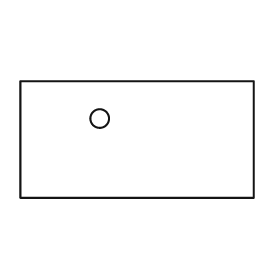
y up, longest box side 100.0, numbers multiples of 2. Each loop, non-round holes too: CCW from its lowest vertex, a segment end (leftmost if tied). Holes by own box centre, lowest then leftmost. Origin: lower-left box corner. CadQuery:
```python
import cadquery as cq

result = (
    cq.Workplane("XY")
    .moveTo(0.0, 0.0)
    .lineTo(100.0, 0.0)
    .lineTo(100.0, 50.0)
    .lineTo(0.0, 50.0)
    .close()
    .moveTo(34.0, 34.0)
    .circle(4.0)
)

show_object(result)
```